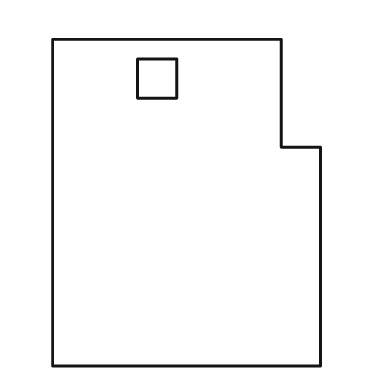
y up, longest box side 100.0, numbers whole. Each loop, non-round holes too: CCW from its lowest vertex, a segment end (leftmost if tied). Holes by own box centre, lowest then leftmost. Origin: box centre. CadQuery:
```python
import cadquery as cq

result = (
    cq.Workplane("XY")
    .moveTo(-41.0, -50.0)
    .lineTo(41.0, -50.0)
    .lineTo(41.0, 17.0)
    .lineTo(29.0, 17.0)
    .lineTo(29.0, 50.0)
    .lineTo(-41.0, 50.0)
    .close()
    .moveTo(-15.0, 32.0)
    .lineTo(-3.0, 32.0)
    .lineTo(-3.0, 44.0)
    .lineTo(-15.0, 44.0)
    .close()
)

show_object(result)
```